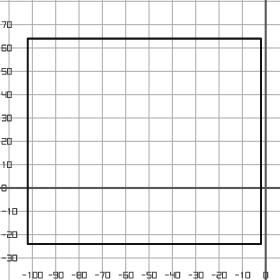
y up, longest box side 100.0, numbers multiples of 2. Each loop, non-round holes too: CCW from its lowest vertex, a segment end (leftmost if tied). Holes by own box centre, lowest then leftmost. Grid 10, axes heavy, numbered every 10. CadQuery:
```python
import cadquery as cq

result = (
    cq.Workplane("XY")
    .moveTo(-102.0, -24.0)
    .lineTo(-2.0, -24.0)
    .lineTo(-2.0, 64.0)
    .lineTo(-102.0, 64.0)
    .close()
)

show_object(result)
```